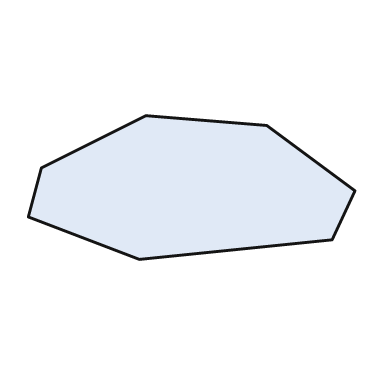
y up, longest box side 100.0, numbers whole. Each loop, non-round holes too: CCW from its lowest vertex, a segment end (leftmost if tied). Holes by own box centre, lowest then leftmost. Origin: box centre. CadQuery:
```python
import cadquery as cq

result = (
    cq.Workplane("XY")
    .moveTo(-16.0, -22.0)
    .lineTo(43.0, -16.0)
    .lineTo(50.0, -1.0)
    .lineTo(23.0, 19.0)
    .lineTo(-14.0, 22.0)
    .lineTo(-46.0, 6.0)
    .lineTo(-50.0, -9.0)
    .close()
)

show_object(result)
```